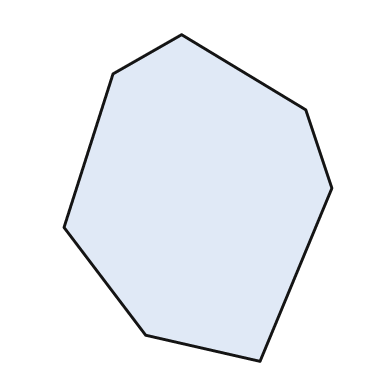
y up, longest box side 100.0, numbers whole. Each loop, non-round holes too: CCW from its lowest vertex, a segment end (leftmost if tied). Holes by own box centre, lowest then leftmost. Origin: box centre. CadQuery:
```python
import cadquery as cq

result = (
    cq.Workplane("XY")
    .moveTo(19.0, -50.0)
    .lineTo(41.0, 3.0)
    .lineTo(33.0, 27.0)
    .lineTo(-5.0, 50.0)
    .lineTo(-26.0, 38.0)
    .lineTo(-41.0, -9.0)
    .lineTo(-16.0, -42.0)
    .close()
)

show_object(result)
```